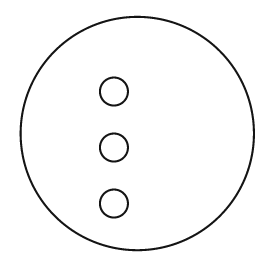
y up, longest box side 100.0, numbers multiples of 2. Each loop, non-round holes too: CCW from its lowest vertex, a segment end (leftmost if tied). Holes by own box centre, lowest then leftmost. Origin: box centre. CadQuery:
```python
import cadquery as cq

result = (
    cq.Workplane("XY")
    .moveTo(0.0, 0.0)
    .circle(50.0)
    .moveTo(-10.0, -30.0)
    .circle(6.0)
    .moveTo(-10.0, -6.0)
    .circle(6.0)
    .moveTo(-10.0, 18.0)
    .circle(6.0)
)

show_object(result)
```